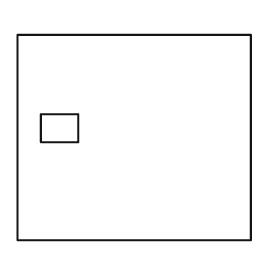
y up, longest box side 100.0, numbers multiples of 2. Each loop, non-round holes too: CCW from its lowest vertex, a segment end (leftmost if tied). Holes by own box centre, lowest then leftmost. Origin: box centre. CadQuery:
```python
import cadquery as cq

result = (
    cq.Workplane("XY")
    .moveTo(-50.0, -44.0)
    .lineTo(50.0, -44.0)
    .lineTo(50.0, 44.0)
    .lineTo(-50.0, 44.0)
    .close()
    .moveTo(-40.0, -2.0)
    .lineTo(-24.0, -2.0)
    .lineTo(-24.0, 10.0)
    .lineTo(-40.0, 10.0)
    .close()
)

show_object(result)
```